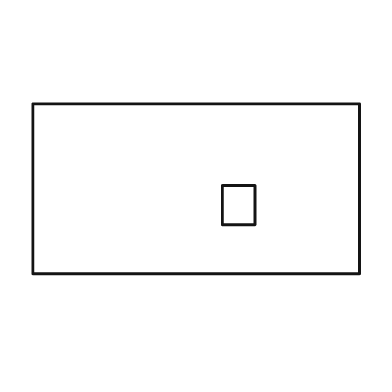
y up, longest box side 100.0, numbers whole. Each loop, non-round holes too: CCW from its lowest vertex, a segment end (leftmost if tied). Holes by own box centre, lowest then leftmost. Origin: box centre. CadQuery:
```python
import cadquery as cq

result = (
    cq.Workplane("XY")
    .moveTo(-50.0, -26.0)
    .lineTo(50.0, -26.0)
    .lineTo(50.0, 26.0)
    .lineTo(-50.0, 26.0)
    .close()
    .moveTo(8.0, -11.0)
    .lineTo(18.0, -11.0)
    .lineTo(18.0, 1.0)
    .lineTo(8.0, 1.0)
    .close()
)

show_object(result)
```